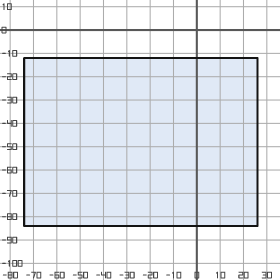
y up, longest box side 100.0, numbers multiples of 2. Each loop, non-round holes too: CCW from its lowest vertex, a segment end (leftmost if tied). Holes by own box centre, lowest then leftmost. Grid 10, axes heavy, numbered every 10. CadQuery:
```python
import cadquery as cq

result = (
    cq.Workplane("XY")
    .moveTo(-74.0, -84.0)
    .lineTo(26.0, -84.0)
    .lineTo(26.0, -12.0)
    .lineTo(-74.0, -12.0)
    .close()
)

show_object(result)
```